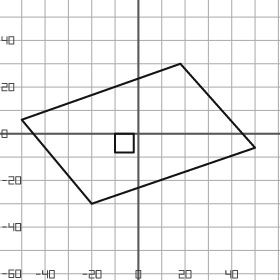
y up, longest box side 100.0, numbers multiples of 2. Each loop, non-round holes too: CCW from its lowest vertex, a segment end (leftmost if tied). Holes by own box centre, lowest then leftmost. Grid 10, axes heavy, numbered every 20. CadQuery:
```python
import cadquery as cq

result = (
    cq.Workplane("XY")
    .moveTo(-20.0, -30.0)
    .lineTo(50.0, -6.0)
    .lineTo(18.0, 30.0)
    .lineTo(-50.0, 6.0)
    .close()
    .moveTo(-10.0, -8.0)
    .lineTo(-2.0, -8.0)
    .lineTo(-2.0, 0.0)
    .lineTo(-10.0, 0.0)
    .close()
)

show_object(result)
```